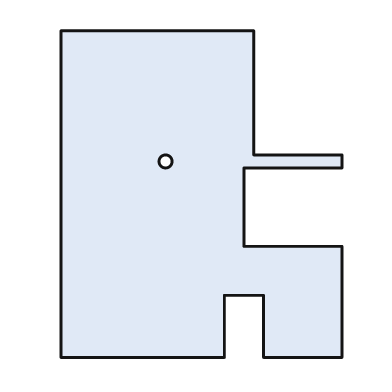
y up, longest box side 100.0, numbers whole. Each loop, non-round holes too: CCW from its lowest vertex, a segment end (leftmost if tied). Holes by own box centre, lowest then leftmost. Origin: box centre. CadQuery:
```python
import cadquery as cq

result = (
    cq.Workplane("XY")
    .moveTo(-43.0, -50.0)
    .lineTo(7.0, -50.0)
    .lineTo(7.0, -31.0)
    .lineTo(19.0, -31.0)
    .lineTo(19.0, -50.0)
    .lineTo(43.0, -50.0)
    .lineTo(43.0, -16.0)
    .lineTo(13.0, -16.0)
    .lineTo(13.0, 8.0)
    .lineTo(43.0, 8.0)
    .lineTo(43.0, 12.0)
    .lineTo(16.0, 12.0)
    .lineTo(16.0, 50.0)
    .lineTo(-43.0, 50.0)
    .close()
    .moveTo(-11.0, 10.0)
    .circle(2.0)
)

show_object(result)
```